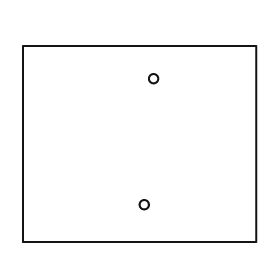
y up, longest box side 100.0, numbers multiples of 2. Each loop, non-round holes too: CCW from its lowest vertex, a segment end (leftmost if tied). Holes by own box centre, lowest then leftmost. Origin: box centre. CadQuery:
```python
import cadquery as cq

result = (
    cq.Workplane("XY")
    .moveTo(-50.0, -42.0)
    .lineTo(50.0, -42.0)
    .lineTo(50.0, 42.0)
    .lineTo(-50.0, 42.0)
    .close()
    .moveTo(2.0, -26.0)
    .circle(2.0)
    .moveTo(6.0, 28.0)
    .circle(2.0)
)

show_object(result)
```